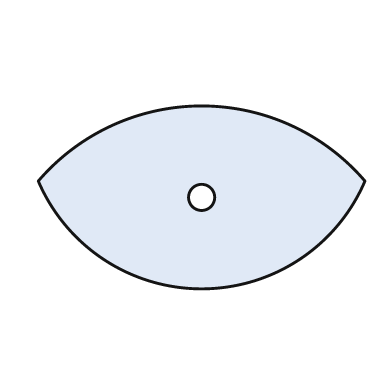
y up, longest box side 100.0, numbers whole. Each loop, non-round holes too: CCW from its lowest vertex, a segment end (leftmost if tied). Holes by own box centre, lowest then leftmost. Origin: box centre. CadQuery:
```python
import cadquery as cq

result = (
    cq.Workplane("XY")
    .moveTo(-50.0, 5.0)
    .threePointArc((0.0, -28.0), (50.0, 5.0))
    .threePointArc((0.0, 28.0), (-50.0, 5.0))
    .close()
    .moveTo(0.0, 0.0)
    .circle(4.0)
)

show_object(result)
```